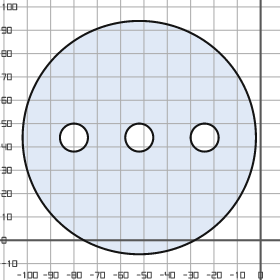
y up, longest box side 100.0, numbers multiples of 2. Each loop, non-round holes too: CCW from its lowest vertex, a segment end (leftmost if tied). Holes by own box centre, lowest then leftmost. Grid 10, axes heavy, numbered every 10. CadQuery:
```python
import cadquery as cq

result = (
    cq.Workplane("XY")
    .moveTo(-52.0, 44.0)
    .circle(50.0)
    .moveTo(-80.0, 44.0)
    .circle(6.0)
    .moveTo(-52.0, 44.0)
    .circle(6.0)
    .moveTo(-24.0, 44.0)
    .circle(6.0)
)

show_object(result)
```